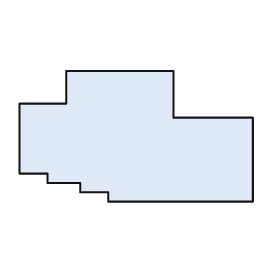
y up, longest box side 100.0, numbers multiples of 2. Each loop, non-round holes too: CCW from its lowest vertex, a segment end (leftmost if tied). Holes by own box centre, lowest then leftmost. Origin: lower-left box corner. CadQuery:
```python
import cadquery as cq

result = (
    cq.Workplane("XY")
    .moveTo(38.0, 0.0)
    .lineTo(100.0, 0.0)
    .lineTo(100.0, 36.0)
    .lineTo(66.0, 36.0)
    .lineTo(66.0, 56.0)
    .lineTo(20.0, 56.0)
    .lineTo(20.0, 42.0)
    .lineTo(0.0, 42.0)
    .lineTo(0.0, 12.0)
    .lineTo(12.0, 12.0)
    .lineTo(12.0, 8.0)
    .lineTo(26.0, 8.0)
    .lineTo(26.0, 4.0)
    .lineTo(38.0, 4.0)
    .close()
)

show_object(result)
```